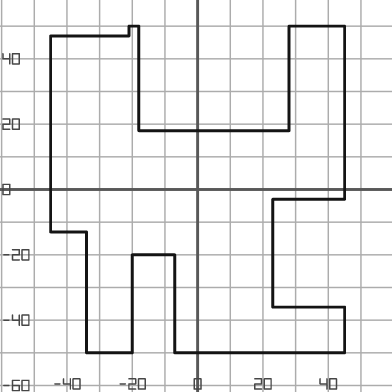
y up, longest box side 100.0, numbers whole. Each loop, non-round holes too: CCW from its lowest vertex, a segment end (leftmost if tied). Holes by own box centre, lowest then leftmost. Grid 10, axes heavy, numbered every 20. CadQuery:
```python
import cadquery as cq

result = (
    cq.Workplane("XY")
    .moveTo(-34.0, -50.0)
    .lineTo(-20.0, -50.0)
    .lineTo(-20.0, -20.0)
    .lineTo(-7.0, -20.0)
    .lineTo(-7.0, -50.0)
    .lineTo(45.0, -50.0)
    .lineTo(45.0, -36.0)
    .lineTo(23.0, -36.0)
    .lineTo(23.0, -3.0)
    .lineTo(45.0, -3.0)
    .lineTo(45.0, 50.0)
    .lineTo(28.0, 50.0)
    .lineTo(28.0, 18.0)
    .lineTo(-18.0, 18.0)
    .lineTo(-18.0, 50.0)
    .lineTo(-21.0, 50.0)
    .lineTo(-21.0, 47.0)
    .lineTo(-45.0, 47.0)
    .lineTo(-45.0, -13.0)
    .lineTo(-34.0, -13.0)
    .close()
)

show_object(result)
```